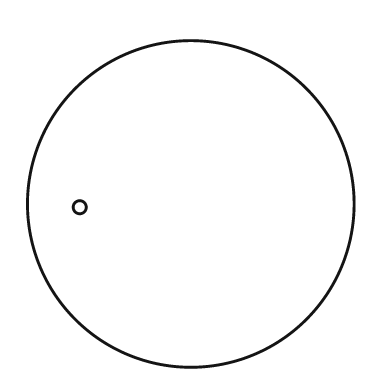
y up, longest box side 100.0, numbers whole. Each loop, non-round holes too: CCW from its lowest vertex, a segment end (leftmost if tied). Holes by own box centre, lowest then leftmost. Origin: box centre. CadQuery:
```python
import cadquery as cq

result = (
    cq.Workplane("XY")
    .moveTo(0.0, 0.0)
    .circle(50.0)
    .moveTo(-34.0, -1.0)
    .circle(2.0)
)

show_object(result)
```